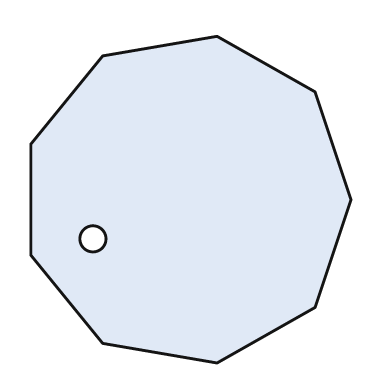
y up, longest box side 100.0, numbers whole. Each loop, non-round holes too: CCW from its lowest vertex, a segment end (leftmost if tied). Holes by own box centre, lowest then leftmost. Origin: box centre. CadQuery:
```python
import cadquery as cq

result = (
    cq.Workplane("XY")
    .moveTo(8.0, -50.0)
    .lineTo(38.0, -33.0)
    .lineTo(49.0, 0.0)
    .lineTo(38.0, 33.0)
    .lineTo(8.0, 50.0)
    .lineTo(-27.0, 44.0)
    .lineTo(-49.0, 17.0)
    .lineTo(-49.0, -17.0)
    .lineTo(-27.0, -44.0)
    .close()
    .moveTo(-30.0, -12.0)
    .circle(4.0)
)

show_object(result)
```